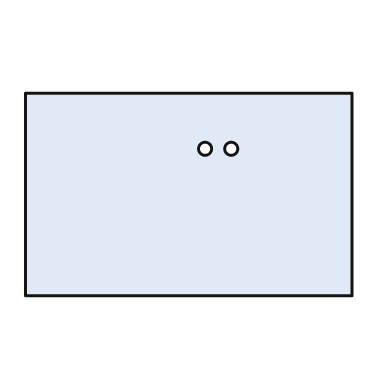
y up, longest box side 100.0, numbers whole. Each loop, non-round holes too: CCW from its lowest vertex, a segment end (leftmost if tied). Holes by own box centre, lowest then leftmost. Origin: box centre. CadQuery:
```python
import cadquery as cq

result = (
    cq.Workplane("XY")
    .moveTo(-50.0, -31.0)
    .lineTo(50.0, -31.0)
    .lineTo(50.0, 31.0)
    .lineTo(-50.0, 31.0)
    .close()
    .moveTo(5.0, 14.0)
    .circle(2.0)
    .moveTo(13.0, 14.0)
    .circle(2.0)
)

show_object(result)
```